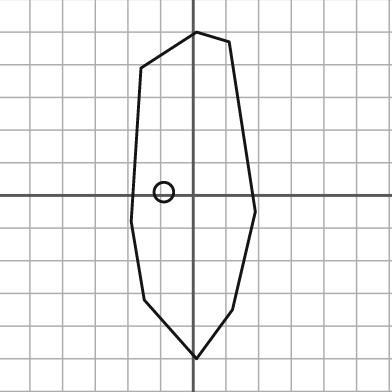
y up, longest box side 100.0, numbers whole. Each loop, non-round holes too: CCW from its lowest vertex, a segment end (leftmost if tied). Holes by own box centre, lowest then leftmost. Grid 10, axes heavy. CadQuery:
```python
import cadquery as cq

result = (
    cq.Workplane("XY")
    .moveTo(1.0, -50.0)
    .lineTo(12.0, -35.0)
    .lineTo(19.0, -5.0)
    .lineTo(11.0, 47.0)
    .lineTo(1.0, 50.0)
    .lineTo(-16.0, 39.0)
    .lineTo(-19.0, -8.0)
    .lineTo(-15.0, -32.0)
    .close()
    .moveTo(-9.0, 1.0)
    .circle(3.0)
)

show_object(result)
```